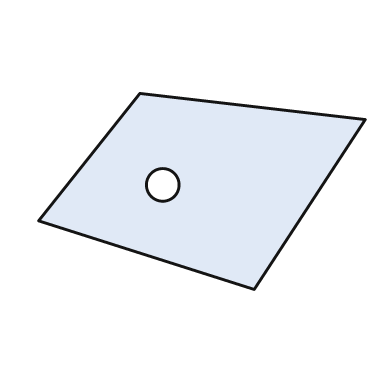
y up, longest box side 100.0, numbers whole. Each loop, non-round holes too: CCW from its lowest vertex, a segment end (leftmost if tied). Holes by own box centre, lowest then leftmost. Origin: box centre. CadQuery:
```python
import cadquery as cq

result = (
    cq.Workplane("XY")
    .moveTo(16.0, -30.0)
    .lineTo(50.0, 22.0)
    .lineTo(-19.0, 30.0)
    .lineTo(-50.0, -9.0)
    .close()
    .moveTo(-12.0, 2.0)
    .circle(5.0)
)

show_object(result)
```